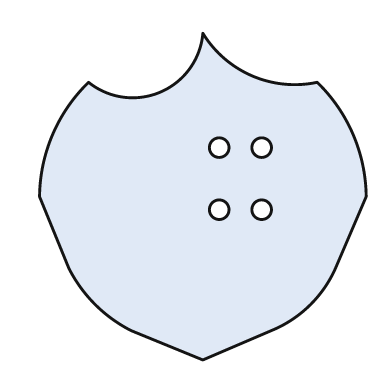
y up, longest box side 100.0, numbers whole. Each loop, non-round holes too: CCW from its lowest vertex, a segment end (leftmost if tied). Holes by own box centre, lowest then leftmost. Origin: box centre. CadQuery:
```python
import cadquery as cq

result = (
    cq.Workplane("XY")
    .moveTo(0.0, -50.0)
    .lineTo(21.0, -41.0)
    .threePointArc((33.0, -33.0), (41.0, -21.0))
    .lineTo(50.0, 0.0)
    .threePointArc((46.0, 19.0), (35.0, 35.0))
    .threePointArc((15.0, 37.0), (0.0, 50.0))
    .threePointArc((-13.0, 32.0), (-35.0, 35.0))
    .threePointArc((-46.0, 19.0), (-50.0, 0.0))
    .lineTo(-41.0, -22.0)
    .threePointArc((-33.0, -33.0), (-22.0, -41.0))
    .close()
    .moveTo(5.0, -4.0)
    .circle(3.0)
    .moveTo(18.0, -4.0)
    .circle(3.0)
    .moveTo(5.0, 15.0)
    .circle(3.0)
    .moveTo(18.0, 15.0)
    .circle(3.0)
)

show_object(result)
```